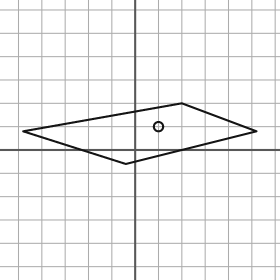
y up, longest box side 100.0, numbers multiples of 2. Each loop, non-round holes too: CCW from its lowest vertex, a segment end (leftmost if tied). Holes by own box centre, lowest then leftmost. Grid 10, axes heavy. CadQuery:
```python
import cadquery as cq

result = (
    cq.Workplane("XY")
    .moveTo(-4.0, -6.0)
    .lineTo(52.0, 8.0)
    .lineTo(20.0, 20.0)
    .lineTo(-48.0, 8.0)
    .close()
    .moveTo(10.0, 10.0)
    .circle(2.0)
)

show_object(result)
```